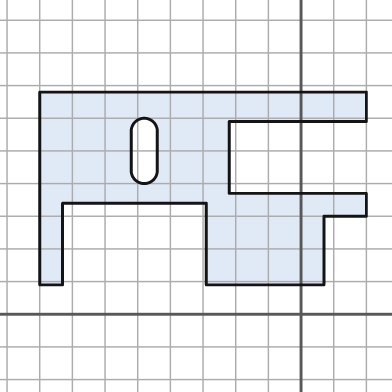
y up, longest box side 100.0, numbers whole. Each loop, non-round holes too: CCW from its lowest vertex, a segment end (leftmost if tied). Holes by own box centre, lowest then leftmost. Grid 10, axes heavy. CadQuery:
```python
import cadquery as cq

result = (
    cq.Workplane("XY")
    .moveTo(-80.0, 9.0)
    .lineTo(-73.0, 9.0)
    .lineTo(-73.0, 34.0)
    .lineTo(-29.0, 34.0)
    .lineTo(-29.0, 9.0)
    .lineTo(7.0, 9.0)
    .lineTo(7.0, 30.0)
    .lineTo(20.0, 30.0)
    .lineTo(20.0, 37.0)
    .lineTo(-22.0, 37.0)
    .lineTo(-22.0, 59.0)
    .lineTo(20.0, 59.0)
    .lineTo(20.0, 68.0)
    .lineTo(-80.0, 68.0)
    .close()
    .moveTo(-52.0, 44.0)
    .threePointArc((-48.0, 40.0), (-44.0, 44.0))
    .lineTo(-44.0, 56.0)
    .threePointArc((-48.0, 60.0), (-52.0, 56.0))
    .close()
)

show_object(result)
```